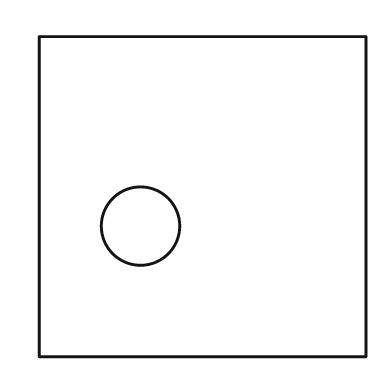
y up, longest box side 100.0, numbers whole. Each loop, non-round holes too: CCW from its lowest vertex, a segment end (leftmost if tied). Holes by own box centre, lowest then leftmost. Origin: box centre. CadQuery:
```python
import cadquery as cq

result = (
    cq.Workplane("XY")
    .moveTo(-50.0, -49.0)
    .lineTo(50.0, -49.0)
    .lineTo(50.0, 49.0)
    .lineTo(-50.0, 49.0)
    .close()
    .moveTo(-19.0, -9.0)
    .circle(12.0)
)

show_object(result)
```